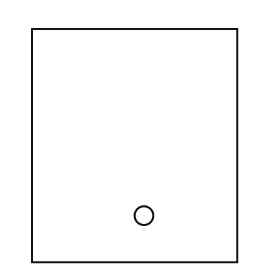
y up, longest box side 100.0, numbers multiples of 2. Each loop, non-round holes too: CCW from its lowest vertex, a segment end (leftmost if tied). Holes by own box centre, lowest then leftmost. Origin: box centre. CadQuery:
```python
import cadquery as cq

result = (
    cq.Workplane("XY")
    .moveTo(-44.0, -50.0)
    .lineTo(44.0, -50.0)
    .lineTo(44.0, 50.0)
    .lineTo(-44.0, 50.0)
    .close()
    .moveTo(4.0, -30.0)
    .circle(4.0)
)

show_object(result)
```